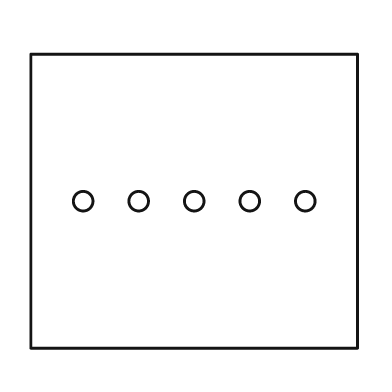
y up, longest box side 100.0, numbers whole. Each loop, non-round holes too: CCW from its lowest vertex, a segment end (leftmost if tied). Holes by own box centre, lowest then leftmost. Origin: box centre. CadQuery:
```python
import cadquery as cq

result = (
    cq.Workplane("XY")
    .moveTo(-50.0, -45.0)
    .lineTo(50.0, -45.0)
    .lineTo(50.0, 45.0)
    .lineTo(-50.0, 45.0)
    .close()
    .moveTo(-34.0, 0.0)
    .circle(3.0)
    .moveTo(-17.0, 0.0)
    .circle(3.0)
    .moveTo(0.0, 0.0)
    .circle(3.0)
    .moveTo(17.0, 0.0)
    .circle(3.0)
    .moveTo(34.0, 0.0)
    .circle(3.0)
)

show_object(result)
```